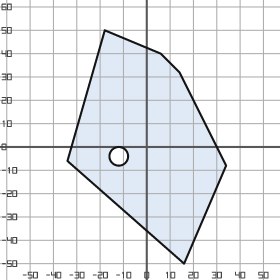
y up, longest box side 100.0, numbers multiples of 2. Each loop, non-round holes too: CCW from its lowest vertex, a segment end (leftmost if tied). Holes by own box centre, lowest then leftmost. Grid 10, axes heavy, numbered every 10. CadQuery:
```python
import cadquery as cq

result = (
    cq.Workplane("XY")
    .moveTo(16.0, -50.0)
    .lineTo(34.0, -8.0)
    .lineTo(14.0, 32.0)
    .lineTo(6.0, 40.0)
    .lineTo(-18.0, 50.0)
    .lineTo(-34.0, -6.0)
    .close()
    .moveTo(-12.0, -4.0)
    .circle(4.0)
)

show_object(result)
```